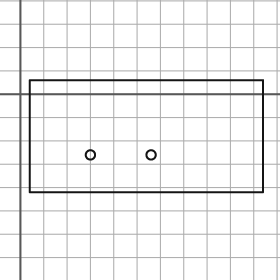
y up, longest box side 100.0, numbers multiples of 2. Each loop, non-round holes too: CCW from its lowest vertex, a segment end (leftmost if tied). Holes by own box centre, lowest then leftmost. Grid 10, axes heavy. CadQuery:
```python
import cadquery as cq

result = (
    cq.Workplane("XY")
    .moveTo(4.0, -42.0)
    .lineTo(104.0, -42.0)
    .lineTo(104.0, 6.0)
    .lineTo(4.0, 6.0)
    .close()
    .moveTo(30.0, -26.0)
    .circle(2.0)
    .moveTo(56.0, -26.0)
    .circle(2.0)
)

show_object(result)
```